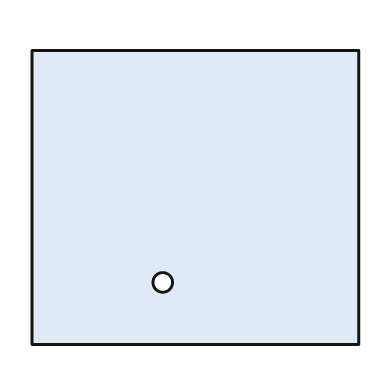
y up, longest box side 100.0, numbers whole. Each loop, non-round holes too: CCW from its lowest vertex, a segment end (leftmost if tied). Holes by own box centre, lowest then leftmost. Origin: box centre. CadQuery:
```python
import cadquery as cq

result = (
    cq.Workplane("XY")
    .moveTo(-50.0, -45.0)
    .lineTo(50.0, -45.0)
    .lineTo(50.0, 45.0)
    .lineTo(-50.0, 45.0)
    .close()
    .moveTo(-10.0, -26.0)
    .circle(3.0)
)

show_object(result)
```